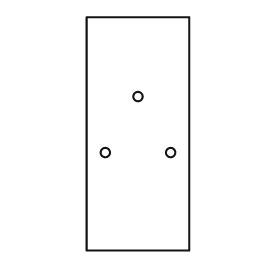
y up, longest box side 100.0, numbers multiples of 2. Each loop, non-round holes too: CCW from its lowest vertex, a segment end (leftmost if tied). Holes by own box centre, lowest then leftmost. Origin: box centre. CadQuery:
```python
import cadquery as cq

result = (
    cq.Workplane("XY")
    .moveTo(-22.0, -50.0)
    .lineTo(22.0, -50.0)
    .lineTo(22.0, 50.0)
    .lineTo(-22.0, 50.0)
    .close()
    .moveTo(-14.0, -8.0)
    .circle(2.0)
    .moveTo(14.0, -8.0)
    .circle(2.0)
    .moveTo(0.0, 16.0)
    .circle(2.0)
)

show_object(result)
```